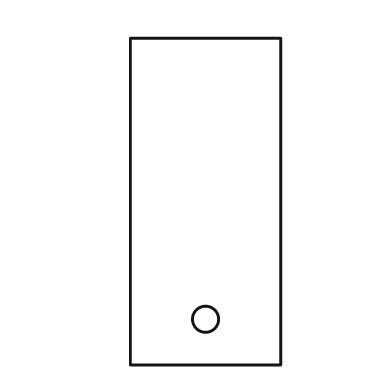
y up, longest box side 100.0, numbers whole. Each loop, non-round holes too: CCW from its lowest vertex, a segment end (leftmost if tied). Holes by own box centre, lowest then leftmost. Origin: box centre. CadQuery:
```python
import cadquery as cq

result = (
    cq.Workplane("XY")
    .moveTo(-23.0, -50.0)
    .lineTo(23.0, -50.0)
    .lineTo(23.0, 50.0)
    .lineTo(-23.0, 50.0)
    .close()
    .moveTo(0.0, -36.0)
    .circle(4.0)
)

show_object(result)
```